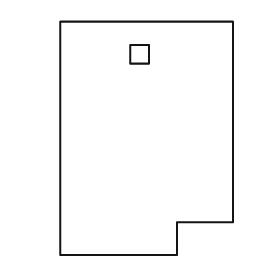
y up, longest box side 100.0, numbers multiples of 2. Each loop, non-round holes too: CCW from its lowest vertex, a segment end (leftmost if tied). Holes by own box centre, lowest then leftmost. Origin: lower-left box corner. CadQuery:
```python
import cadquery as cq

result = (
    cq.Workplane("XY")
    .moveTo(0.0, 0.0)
    .lineTo(50.0, 0.0)
    .lineTo(50.0, 14.0)
    .lineTo(74.0, 14.0)
    .lineTo(74.0, 100.0)
    .lineTo(0.0, 100.0)
    .close()
    .moveTo(30.0, 82.0)
    .lineTo(38.0, 82.0)
    .lineTo(38.0, 90.0)
    .lineTo(30.0, 90.0)
    .close()
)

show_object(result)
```